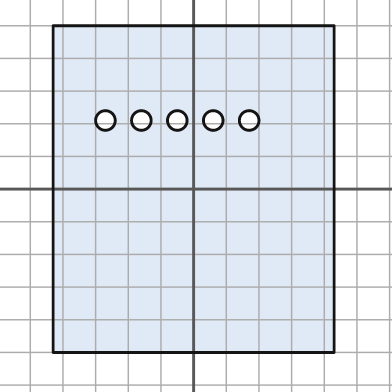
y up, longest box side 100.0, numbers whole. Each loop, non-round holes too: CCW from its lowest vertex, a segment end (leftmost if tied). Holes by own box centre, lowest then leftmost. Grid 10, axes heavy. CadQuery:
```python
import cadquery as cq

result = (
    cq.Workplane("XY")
    .moveTo(-43.0, -50.0)
    .lineTo(43.0, -50.0)
    .lineTo(43.0, 50.0)
    .lineTo(-43.0, 50.0)
    .close()
    .moveTo(-27.0, 21.0)
    .circle(3.0)
    .moveTo(-16.0, 21.0)
    .circle(3.0)
    .moveTo(-5.0, 21.0)
    .circle(3.0)
    .moveTo(6.0, 21.0)
    .circle(3.0)
    .moveTo(17.0, 21.0)
    .circle(3.0)
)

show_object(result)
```